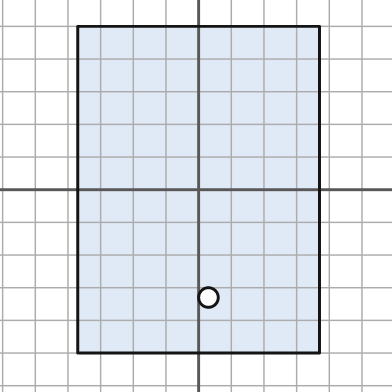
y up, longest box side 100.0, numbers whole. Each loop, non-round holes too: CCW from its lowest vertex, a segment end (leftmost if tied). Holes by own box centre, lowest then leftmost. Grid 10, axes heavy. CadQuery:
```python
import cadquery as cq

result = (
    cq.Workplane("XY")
    .moveTo(-37.0, -50.0)
    .lineTo(37.0, -50.0)
    .lineTo(37.0, 50.0)
    .lineTo(-37.0, 50.0)
    .close()
    .moveTo(3.0, -33.0)
    .circle(3.0)
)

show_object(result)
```